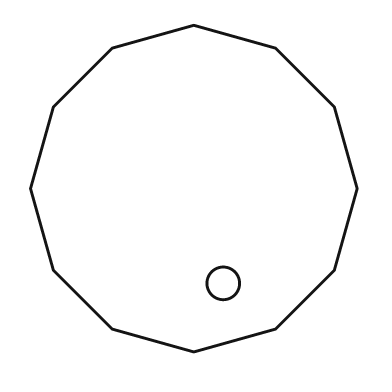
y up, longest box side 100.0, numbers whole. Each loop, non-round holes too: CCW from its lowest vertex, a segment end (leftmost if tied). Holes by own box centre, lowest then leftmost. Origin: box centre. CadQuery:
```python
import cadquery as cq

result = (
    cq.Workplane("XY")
    .moveTo(0.0, -50.0)
    .lineTo(25.0, -43.0)
    .lineTo(43.0, -25.0)
    .lineTo(50.0, 0.0)
    .lineTo(43.0, 25.0)
    .lineTo(25.0, 43.0)
    .lineTo(0.0, 50.0)
    .lineTo(-25.0, 43.0)
    .lineTo(-43.0, 25.0)
    .lineTo(-50.0, 0.0)
    .lineTo(-43.0, -25.0)
    .lineTo(-25.0, -43.0)
    .close()
    .moveTo(9.0, -29.0)
    .circle(5.0)
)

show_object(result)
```